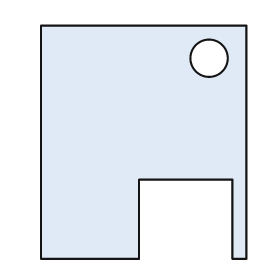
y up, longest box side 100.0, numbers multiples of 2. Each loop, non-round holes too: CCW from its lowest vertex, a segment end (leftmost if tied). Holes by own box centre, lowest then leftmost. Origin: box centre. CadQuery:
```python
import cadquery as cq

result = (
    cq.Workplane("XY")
    .moveTo(-44.0, -50.0)
    .lineTo(-2.0, -50.0)
    .lineTo(-2.0, -16.0)
    .lineTo(38.0, -16.0)
    .lineTo(38.0, -50.0)
    .lineTo(44.0, -50.0)
    .lineTo(44.0, 50.0)
    .lineTo(-44.0, 50.0)
    .close()
    .moveTo(28.0, 36.0)
    .circle(8.0)
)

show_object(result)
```